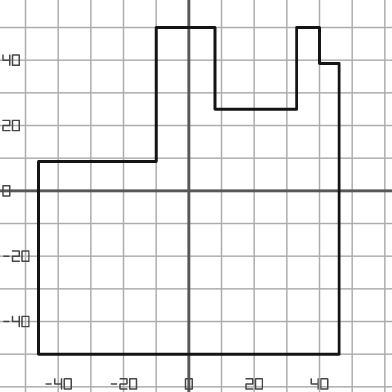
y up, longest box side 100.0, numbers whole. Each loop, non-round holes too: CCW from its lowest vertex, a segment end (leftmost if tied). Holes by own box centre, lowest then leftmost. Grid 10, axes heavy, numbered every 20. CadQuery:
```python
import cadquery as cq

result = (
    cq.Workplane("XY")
    .moveTo(-46.0, -50.0)
    .lineTo(46.0, -50.0)
    .lineTo(46.0, 39.0)
    .lineTo(40.0, 39.0)
    .lineTo(40.0, 50.0)
    .lineTo(33.0, 50.0)
    .lineTo(33.0, 25.0)
    .lineTo(8.0, 25.0)
    .lineTo(8.0, 50.0)
    .lineTo(-10.0, 50.0)
    .lineTo(-10.0, 9.0)
    .lineTo(-46.0, 9.0)
    .close()
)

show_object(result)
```